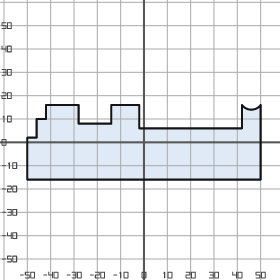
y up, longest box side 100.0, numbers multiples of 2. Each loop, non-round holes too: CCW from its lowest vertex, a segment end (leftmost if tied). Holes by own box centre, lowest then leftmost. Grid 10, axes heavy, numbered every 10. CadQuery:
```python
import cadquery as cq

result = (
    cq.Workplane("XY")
    .moveTo(-50.0, -16.0)
    .lineTo(50.0, -16.0)
    .lineTo(50.0, 16.0)
    .threePointArc((46.0, 14.0), (42.0, 16.0))
    .lineTo(42.0, 6.0)
    .lineTo(-2.0, 6.0)
    .lineTo(-2.0, 16.0)
    .lineTo(-14.0, 16.0)
    .lineTo(-14.0, 8.0)
    .lineTo(-28.0, 8.0)
    .lineTo(-28.0, 16.0)
    .lineTo(-42.0, 16.0)
    .lineTo(-42.0, 10.0)
    .lineTo(-46.0, 10.0)
    .lineTo(-46.0, 2.0)
    .lineTo(-50.0, 2.0)
    .close()
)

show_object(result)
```